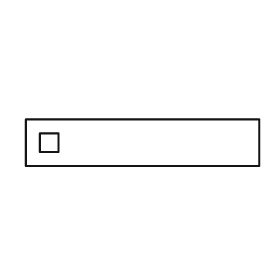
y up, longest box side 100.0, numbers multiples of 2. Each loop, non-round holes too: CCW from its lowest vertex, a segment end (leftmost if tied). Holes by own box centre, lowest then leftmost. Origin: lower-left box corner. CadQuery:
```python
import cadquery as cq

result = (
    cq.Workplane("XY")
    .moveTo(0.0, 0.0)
    .lineTo(100.0, 0.0)
    .lineTo(100.0, 20.0)
    .lineTo(0.0, 20.0)
    .close()
    .moveTo(6.0, 6.0)
    .lineTo(14.0, 6.0)
    .lineTo(14.0, 14.0)
    .lineTo(6.0, 14.0)
    .close()
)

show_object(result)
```